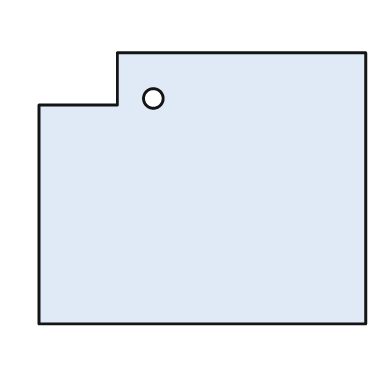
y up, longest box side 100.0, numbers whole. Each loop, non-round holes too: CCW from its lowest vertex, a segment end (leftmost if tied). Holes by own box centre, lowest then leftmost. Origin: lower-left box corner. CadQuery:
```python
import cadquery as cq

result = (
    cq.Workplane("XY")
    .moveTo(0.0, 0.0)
    .lineTo(100.0, 0.0)
    .lineTo(100.0, 83.0)
    .lineTo(24.0, 83.0)
    .lineTo(24.0, 67.0)
    .lineTo(0.0, 67.0)
    .close()
    .moveTo(35.0, 69.0)
    .circle(3.0)
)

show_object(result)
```